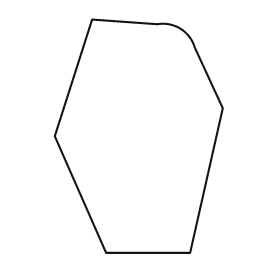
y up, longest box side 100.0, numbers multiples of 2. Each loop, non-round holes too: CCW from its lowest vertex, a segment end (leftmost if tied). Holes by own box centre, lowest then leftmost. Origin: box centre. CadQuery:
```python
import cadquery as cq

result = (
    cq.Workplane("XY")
    .moveTo(-14.0, -50.0)
    .lineTo(22.0, -50.0)
    .lineTo(36.0, 12.0)
    .lineTo(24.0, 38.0)
    .threePointArc((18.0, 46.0), (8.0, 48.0))
    .lineTo(-20.0, 50.0)
    .lineTo(-36.0, 0.0)
    .close()
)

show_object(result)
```